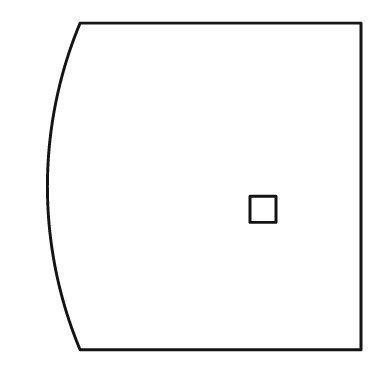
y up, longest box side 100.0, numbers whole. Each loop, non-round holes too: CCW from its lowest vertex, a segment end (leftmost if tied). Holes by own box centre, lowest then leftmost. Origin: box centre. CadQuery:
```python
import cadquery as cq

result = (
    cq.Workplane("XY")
    .moveTo(-38.0, -50.0)
    .lineTo(48.0, -50.0)
    .lineTo(48.0, 50.0)
    .lineTo(-38.0, 50.0)
    .threePointArc((-48.0, 0.0), (-38.0, -50.0))
    .close()
    .moveTo(14.0, -11.0)
    .lineTo(22.0, -11.0)
    .lineTo(22.0, -3.0)
    .lineTo(14.0, -3.0)
    .close()
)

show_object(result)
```